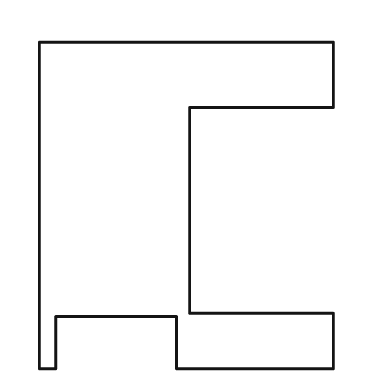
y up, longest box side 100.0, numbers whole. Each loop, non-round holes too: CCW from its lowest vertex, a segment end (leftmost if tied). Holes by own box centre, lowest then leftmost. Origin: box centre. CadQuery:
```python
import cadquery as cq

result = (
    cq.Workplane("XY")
    .moveTo(-45.0, -50.0)
    .lineTo(-40.0, -50.0)
    .lineTo(-40.0, -34.0)
    .lineTo(-3.0, -34.0)
    .lineTo(-3.0, -50.0)
    .lineTo(45.0, -50.0)
    .lineTo(45.0, -33.0)
    .lineTo(1.0, -33.0)
    .lineTo(1.0, 30.0)
    .lineTo(45.0, 30.0)
    .lineTo(45.0, 50.0)
    .lineTo(-45.0, 50.0)
    .close()
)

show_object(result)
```